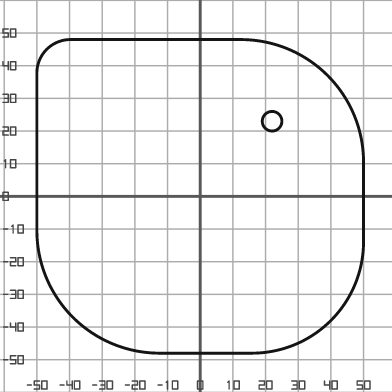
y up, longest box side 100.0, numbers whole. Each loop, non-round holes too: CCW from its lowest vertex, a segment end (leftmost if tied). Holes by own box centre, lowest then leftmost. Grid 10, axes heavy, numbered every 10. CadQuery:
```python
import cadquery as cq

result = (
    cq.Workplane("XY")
    .moveTo(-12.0, -48.0)
    .lineTo(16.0, -48.0)
    .threePointArc((40.0, -38.0), (50.0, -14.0))
    .lineTo(50.0, 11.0)
    .threePointArc((39.0, 37.0), (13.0, 48.0))
    .lineTo(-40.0, 48.0)
    .threePointArc((-47.0, 45.0), (-50.0, 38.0))
    .lineTo(-50.0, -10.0)
    .threePointArc((-39.0, -37.0), (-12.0, -48.0))
    .close()
    .moveTo(22.0, 23.0)
    .circle(3.0)
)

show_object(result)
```